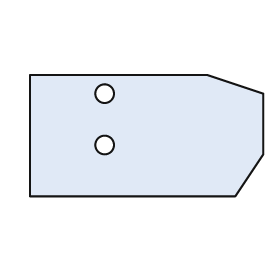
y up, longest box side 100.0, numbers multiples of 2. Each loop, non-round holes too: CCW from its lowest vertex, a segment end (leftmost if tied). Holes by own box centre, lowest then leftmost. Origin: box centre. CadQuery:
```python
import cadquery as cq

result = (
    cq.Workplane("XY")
    .moveTo(-50.0, -26.0)
    .lineTo(38.0, -26.0)
    .lineTo(50.0, -8.0)
    .lineTo(50.0, 18.0)
    .lineTo(26.0, 26.0)
    .lineTo(-50.0, 26.0)
    .close()
    .moveTo(-18.0, -4.0)
    .circle(4.0)
    .moveTo(-18.0, 18.0)
    .circle(4.0)
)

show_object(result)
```